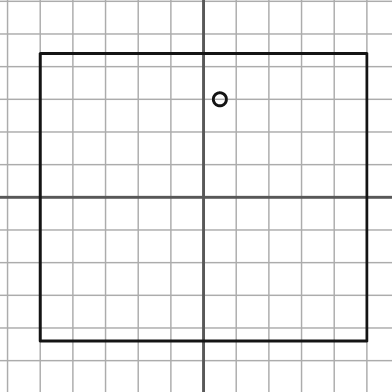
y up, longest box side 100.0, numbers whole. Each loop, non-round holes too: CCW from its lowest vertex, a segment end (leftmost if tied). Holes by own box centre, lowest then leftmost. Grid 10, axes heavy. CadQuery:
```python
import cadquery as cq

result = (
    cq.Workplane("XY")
    .moveTo(-50.0, -44.0)
    .lineTo(50.0, -44.0)
    .lineTo(50.0, 44.0)
    .lineTo(-50.0, 44.0)
    .close()
    .moveTo(5.0, 30.0)
    .circle(2.0)
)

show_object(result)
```